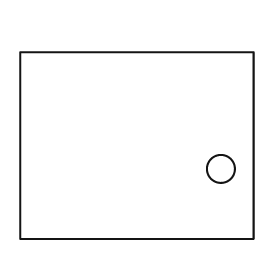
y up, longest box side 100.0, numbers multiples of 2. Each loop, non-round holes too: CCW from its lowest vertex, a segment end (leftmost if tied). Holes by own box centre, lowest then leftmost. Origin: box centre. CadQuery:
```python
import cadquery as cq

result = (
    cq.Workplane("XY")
    .moveTo(-50.0, -40.0)
    .lineTo(50.0, -40.0)
    .lineTo(50.0, 40.0)
    .lineTo(-50.0, 40.0)
    .close()
    .moveTo(36.0, -10.0)
    .circle(6.0)
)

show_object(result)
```